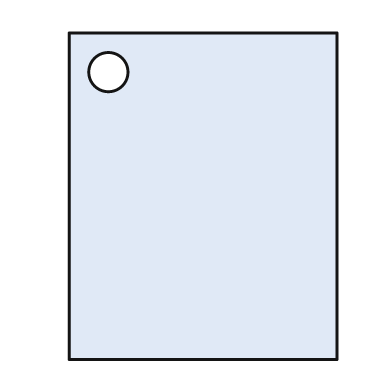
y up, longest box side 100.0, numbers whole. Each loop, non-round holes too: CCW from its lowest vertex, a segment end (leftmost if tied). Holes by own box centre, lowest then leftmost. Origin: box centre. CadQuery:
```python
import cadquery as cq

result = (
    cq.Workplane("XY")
    .moveTo(-41.0, -50.0)
    .lineTo(41.0, -50.0)
    .lineTo(41.0, 50.0)
    .lineTo(-41.0, 50.0)
    .close()
    .moveTo(-29.0, 38.0)
    .circle(6.0)
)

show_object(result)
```